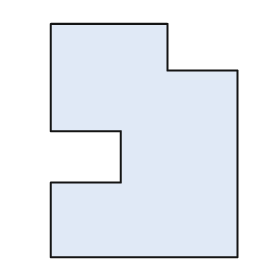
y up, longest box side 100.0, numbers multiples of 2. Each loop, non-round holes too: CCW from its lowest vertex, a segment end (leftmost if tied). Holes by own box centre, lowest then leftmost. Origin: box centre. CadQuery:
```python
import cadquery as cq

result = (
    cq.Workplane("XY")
    .moveTo(-40.0, -50.0)
    .lineTo(40.0, -50.0)
    .lineTo(40.0, 30.0)
    .lineTo(10.0, 30.0)
    .lineTo(10.0, 50.0)
    .lineTo(-40.0, 50.0)
    .lineTo(-40.0, 4.0)
    .lineTo(-10.0, 4.0)
    .lineTo(-10.0, -18.0)
    .lineTo(-40.0, -18.0)
    .close()
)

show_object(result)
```